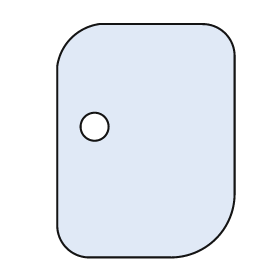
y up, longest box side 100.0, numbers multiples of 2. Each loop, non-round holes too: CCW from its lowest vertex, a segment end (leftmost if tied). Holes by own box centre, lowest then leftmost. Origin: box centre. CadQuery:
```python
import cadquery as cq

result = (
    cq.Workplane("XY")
    .moveTo(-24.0, -50.0)
    .lineTo(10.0, -50.0)
    .threePointArc((30.0, -42.0), (38.0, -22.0))
    .lineTo(38.0, 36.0)
    .threePointArc((34.0, 46.0), (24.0, 50.0))
    .lineTo(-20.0, 50.0)
    .threePointArc((-32.0, 44.0), (-38.0, 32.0))
    .lineTo(-38.0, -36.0)
    .threePointArc((-34.0, -46.0), (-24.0, -50.0))
    .close()
    .moveTo(-22.0, 6.0)
    .circle(6.0)
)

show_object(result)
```